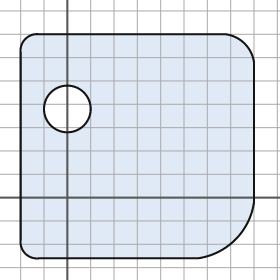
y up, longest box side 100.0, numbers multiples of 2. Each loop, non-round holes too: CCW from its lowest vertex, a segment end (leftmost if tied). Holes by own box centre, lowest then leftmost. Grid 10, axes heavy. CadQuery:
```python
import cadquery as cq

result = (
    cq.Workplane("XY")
    .moveTo(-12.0, -26.0)
    .lineTo(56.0, -26.0)
    .threePointArc((72.0, -18.0), (80.0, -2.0))
    .lineTo(80.0, 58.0)
    .threePointArc((76.0, 66.0), (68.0, 70.0))
    .lineTo(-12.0, 70.0)
    .threePointArc((-18.0, 68.0), (-20.0, 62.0))
    .lineTo(-20.0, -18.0)
    .threePointArc((-18.0, -24.0), (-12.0, -26.0))
    .close()
    .moveTo(0.0, 38.0)
    .circle(10.0)
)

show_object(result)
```